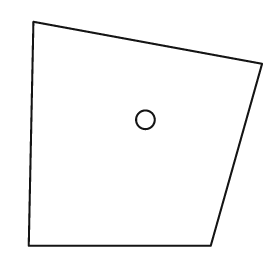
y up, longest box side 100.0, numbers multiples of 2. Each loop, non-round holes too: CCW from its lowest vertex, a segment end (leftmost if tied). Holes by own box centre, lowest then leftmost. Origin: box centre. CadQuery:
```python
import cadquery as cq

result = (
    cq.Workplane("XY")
    .moveTo(-50.0, -48.0)
    .lineTo(28.0, -48.0)
    .lineTo(50.0, 30.0)
    .lineTo(-48.0, 48.0)
    .close()
    .moveTo(0.0, 6.0)
    .circle(4.0)
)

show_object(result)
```